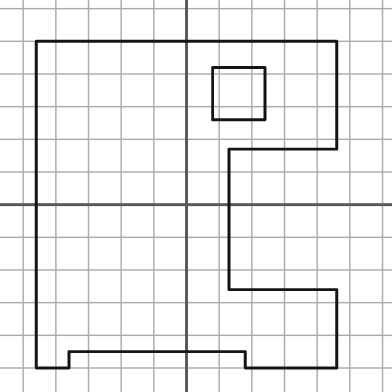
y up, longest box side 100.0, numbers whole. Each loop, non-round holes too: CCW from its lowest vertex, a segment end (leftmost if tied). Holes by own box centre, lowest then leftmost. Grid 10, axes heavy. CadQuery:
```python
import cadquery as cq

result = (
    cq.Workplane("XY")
    .moveTo(-46.0, -50.0)
    .lineTo(-36.0, -50.0)
    .lineTo(-36.0, -45.0)
    .lineTo(18.0, -45.0)
    .lineTo(18.0, -50.0)
    .lineTo(46.0, -50.0)
    .lineTo(46.0, -26.0)
    .lineTo(13.0, -26.0)
    .lineTo(13.0, 17.0)
    .lineTo(46.0, 17.0)
    .lineTo(46.0, 50.0)
    .lineTo(-46.0, 50.0)
    .close()
    .moveTo(8.0, 26.0)
    .lineTo(24.0, 26.0)
    .lineTo(24.0, 42.0)
    .lineTo(8.0, 42.0)
    .close()
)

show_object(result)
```